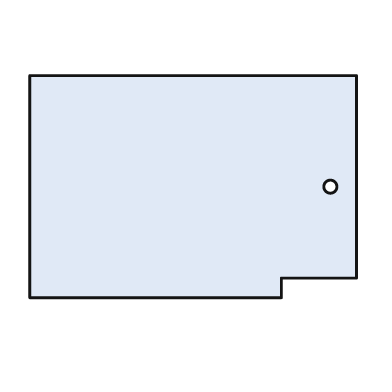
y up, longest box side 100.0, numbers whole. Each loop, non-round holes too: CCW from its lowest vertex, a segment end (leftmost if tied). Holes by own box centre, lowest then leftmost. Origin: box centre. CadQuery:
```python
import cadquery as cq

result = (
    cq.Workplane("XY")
    .moveTo(-50.0, -34.0)
    .lineTo(27.0, -34.0)
    .lineTo(27.0, -28.0)
    .lineTo(50.0, -28.0)
    .lineTo(50.0, 34.0)
    .lineTo(-50.0, 34.0)
    .close()
    .moveTo(42.0, 0.0)
    .circle(2.0)
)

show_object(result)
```